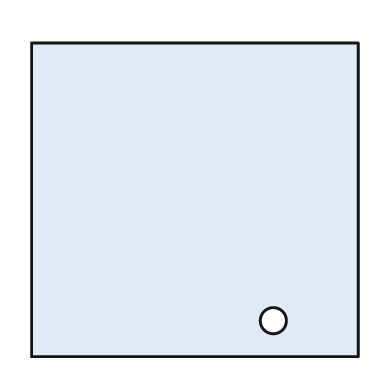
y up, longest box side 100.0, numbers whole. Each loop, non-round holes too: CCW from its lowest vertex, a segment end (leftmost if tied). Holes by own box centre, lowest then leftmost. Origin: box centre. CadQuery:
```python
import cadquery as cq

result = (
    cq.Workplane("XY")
    .moveTo(-50.0, -48.0)
    .lineTo(50.0, -48.0)
    .lineTo(50.0, 48.0)
    .lineTo(-50.0, 48.0)
    .close()
    .moveTo(24.0, -37.0)
    .circle(4.0)
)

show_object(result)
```